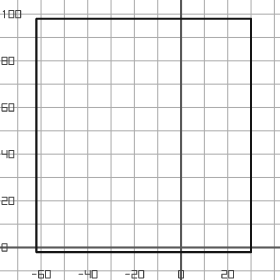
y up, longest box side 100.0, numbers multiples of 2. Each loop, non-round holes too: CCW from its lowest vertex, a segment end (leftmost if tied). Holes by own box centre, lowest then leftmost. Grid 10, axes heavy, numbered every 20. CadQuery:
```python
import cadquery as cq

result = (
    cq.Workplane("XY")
    .moveTo(-62.0, -2.0)
    .lineTo(30.0, -2.0)
    .lineTo(30.0, 98.0)
    .lineTo(-62.0, 98.0)
    .close()
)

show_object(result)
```